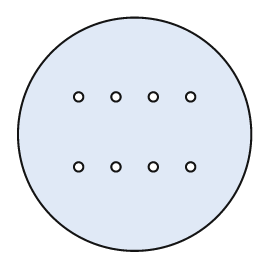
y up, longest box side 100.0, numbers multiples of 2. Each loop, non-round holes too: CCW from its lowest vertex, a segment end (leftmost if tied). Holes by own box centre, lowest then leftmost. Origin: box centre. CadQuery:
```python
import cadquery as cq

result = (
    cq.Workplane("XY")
    .moveTo(0.0, 0.0)
    .circle(50.0)
    .moveTo(-24.0, -14.0)
    .circle(2.0)
    .moveTo(-8.0, -14.0)
    .circle(2.0)
    .moveTo(8.0, -14.0)
    .circle(2.0)
    .moveTo(24.0, -14.0)
    .circle(2.0)
    .moveTo(-24.0, 16.0)
    .circle(2.0)
    .moveTo(-8.0, 16.0)
    .circle(2.0)
    .moveTo(8.0, 16.0)
    .circle(2.0)
    .moveTo(24.0, 16.0)
    .circle(2.0)
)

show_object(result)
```